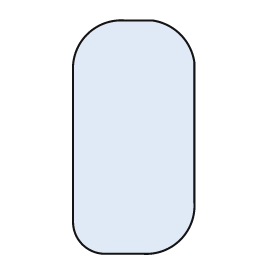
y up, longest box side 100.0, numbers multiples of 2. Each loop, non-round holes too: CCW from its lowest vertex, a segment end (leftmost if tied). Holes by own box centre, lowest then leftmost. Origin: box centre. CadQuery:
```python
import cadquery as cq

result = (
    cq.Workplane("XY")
    .moveTo(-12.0, -50.0)
    .lineTo(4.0, -50.0)
    .threePointArc((20.0, -44.0), (26.0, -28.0))
    .lineTo(26.0, 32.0)
    .threePointArc((20.0, 44.0), (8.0, 50.0))
    .lineTo(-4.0, 50.0)
    .threePointArc((-20.0, 44.0), (-26.0, 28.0))
    .lineTo(-26.0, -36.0)
    .threePointArc((-22.0, -46.0), (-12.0, -50.0))
    .close()
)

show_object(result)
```